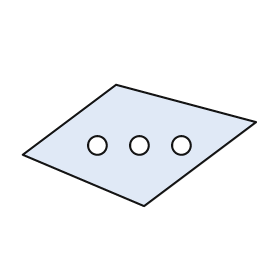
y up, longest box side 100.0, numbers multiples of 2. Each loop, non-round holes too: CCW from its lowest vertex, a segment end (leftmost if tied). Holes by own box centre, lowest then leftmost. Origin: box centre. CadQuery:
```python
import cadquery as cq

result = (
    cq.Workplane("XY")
    .moveTo(2.0, -26.0)
    .lineTo(50.0, 10.0)
    .lineTo(-10.0, 26.0)
    .lineTo(-50.0, -4.0)
    .close()
    .moveTo(-18.0, 0.0)
    .circle(4.0)
    .moveTo(0.0, 0.0)
    .circle(4.0)
    .moveTo(18.0, 0.0)
    .circle(4.0)
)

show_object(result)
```